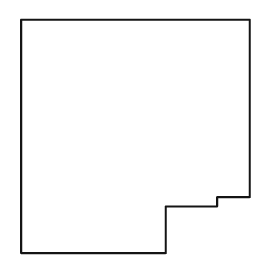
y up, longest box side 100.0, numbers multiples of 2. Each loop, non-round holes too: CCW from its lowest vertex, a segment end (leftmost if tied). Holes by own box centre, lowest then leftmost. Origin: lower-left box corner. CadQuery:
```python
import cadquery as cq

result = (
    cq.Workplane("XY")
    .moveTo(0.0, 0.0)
    .lineTo(62.0, 0.0)
    .lineTo(62.0, 20.0)
    .lineTo(84.0, 20.0)
    .lineTo(84.0, 24.0)
    .lineTo(98.0, 24.0)
    .lineTo(98.0, 100.0)
    .lineTo(0.0, 100.0)
    .close()
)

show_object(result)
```